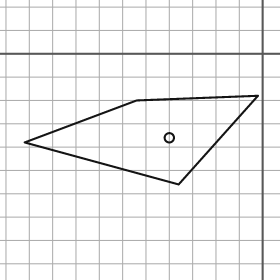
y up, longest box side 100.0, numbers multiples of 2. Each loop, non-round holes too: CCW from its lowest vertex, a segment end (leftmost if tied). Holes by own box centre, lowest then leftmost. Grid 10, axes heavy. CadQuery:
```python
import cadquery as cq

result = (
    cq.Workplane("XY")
    .moveTo(-36.0, -56.0)
    .lineTo(-2.0, -18.0)
    .lineTo(-54.0, -20.0)
    .lineTo(-102.0, -38.0)
    .close()
    .moveTo(-40.0, -36.0)
    .circle(2.0)
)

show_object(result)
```